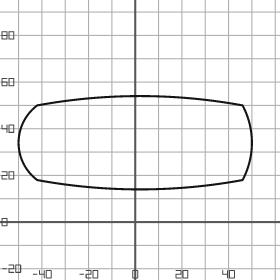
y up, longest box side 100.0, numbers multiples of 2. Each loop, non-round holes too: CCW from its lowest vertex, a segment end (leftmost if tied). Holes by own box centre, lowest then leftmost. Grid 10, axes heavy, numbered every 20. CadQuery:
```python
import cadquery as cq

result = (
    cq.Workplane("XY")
    .moveTo(-42.0, 18.0)
    .threePointArc((2.0, 14.0), (46.0, 18.0))
    .threePointArc((50.0, 34.0), (46.0, 50.0))
    .threePointArc((2.0, 54.0), (-42.0, 50.0))
    .threePointArc((-50.0, 34.0), (-42.0, 18.0))
    .close()
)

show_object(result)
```